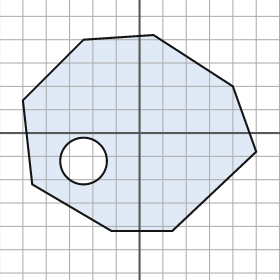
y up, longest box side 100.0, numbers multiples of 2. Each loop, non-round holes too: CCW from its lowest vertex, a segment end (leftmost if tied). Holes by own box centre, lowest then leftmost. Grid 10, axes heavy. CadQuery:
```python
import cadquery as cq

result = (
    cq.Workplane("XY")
    .moveTo(-12.0, -42.0)
    .lineTo(14.0, -42.0)
    .lineTo(50.0, -8.0)
    .lineTo(40.0, 20.0)
    .lineTo(6.0, 42.0)
    .lineTo(-24.0, 40.0)
    .lineTo(-50.0, 14.0)
    .lineTo(-46.0, -22.0)
    .close()
    .moveTo(-24.0, -12.0)
    .circle(10.0)
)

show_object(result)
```